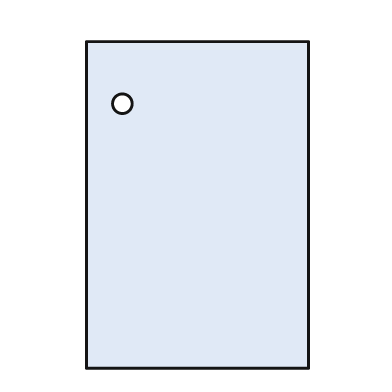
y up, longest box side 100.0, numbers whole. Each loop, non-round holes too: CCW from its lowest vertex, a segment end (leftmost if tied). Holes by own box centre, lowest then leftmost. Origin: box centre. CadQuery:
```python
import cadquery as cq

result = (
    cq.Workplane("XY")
    .moveTo(-34.0, -50.0)
    .lineTo(34.0, -50.0)
    .lineTo(34.0, 50.0)
    .lineTo(-34.0, 50.0)
    .close()
    .moveTo(-23.0, 31.0)
    .circle(3.0)
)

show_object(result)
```